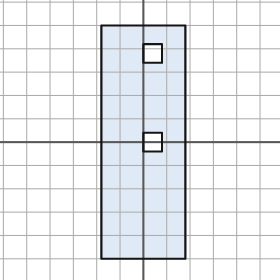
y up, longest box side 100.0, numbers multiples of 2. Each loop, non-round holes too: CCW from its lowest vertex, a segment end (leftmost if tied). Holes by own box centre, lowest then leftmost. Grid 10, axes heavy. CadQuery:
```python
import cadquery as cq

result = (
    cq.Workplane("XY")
    .moveTo(-18.0, -50.0)
    .lineTo(18.0, -50.0)
    .lineTo(18.0, 50.0)
    .lineTo(-18.0, 50.0)
    .close()
    .moveTo(0.0, -4.0)
    .lineTo(8.0, -4.0)
    .lineTo(8.0, 4.0)
    .lineTo(0.0, 4.0)
    .close()
    .moveTo(0.0, 34.0)
    .lineTo(8.0, 34.0)
    .lineTo(8.0, 42.0)
    .lineTo(0.0, 42.0)
    .close()
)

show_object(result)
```